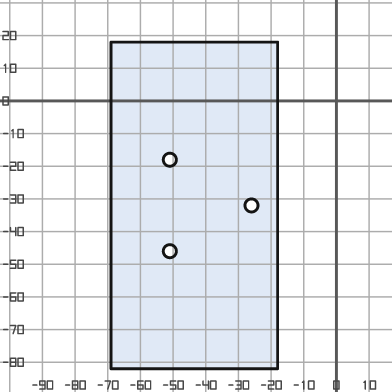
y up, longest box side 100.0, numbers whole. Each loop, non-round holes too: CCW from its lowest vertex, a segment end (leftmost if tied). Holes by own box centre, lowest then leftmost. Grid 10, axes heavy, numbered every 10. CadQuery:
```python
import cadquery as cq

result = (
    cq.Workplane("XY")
    .moveTo(-69.0, -82.0)
    .lineTo(-18.0, -82.0)
    .lineTo(-18.0, 18.0)
    .lineTo(-69.0, 18.0)
    .close()
    .moveTo(-51.0, -46.0)
    .circle(2.0)
    .moveTo(-26.0, -32.0)
    .circle(2.0)
    .moveTo(-51.0, -18.0)
    .circle(2.0)
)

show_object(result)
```